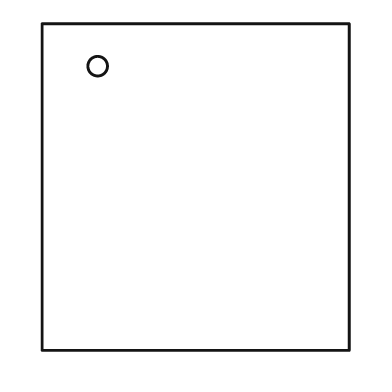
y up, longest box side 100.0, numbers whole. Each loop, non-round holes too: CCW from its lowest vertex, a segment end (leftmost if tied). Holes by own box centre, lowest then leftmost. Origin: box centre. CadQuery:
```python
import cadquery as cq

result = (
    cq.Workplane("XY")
    .moveTo(-47.0, -50.0)
    .lineTo(47.0, -50.0)
    .lineTo(47.0, 50.0)
    .lineTo(-47.0, 50.0)
    .close()
    .moveTo(-30.0, 37.0)
    .circle(3.0)
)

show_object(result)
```